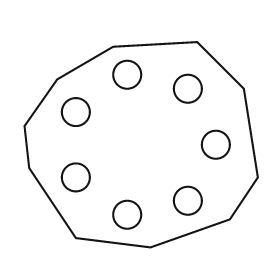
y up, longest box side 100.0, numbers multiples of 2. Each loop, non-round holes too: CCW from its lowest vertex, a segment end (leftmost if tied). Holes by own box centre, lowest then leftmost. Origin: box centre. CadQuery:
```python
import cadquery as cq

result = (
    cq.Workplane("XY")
    .moveTo(4.0, -44.0)
    .lineTo(38.0, -32.0)
    .lineTo(50.0, -14.0)
    .lineTo(44.0, 24.0)
    .lineTo(24.0, 44.0)
    .lineTo(-12.0, 42.0)
    .lineTo(-36.0, 28.0)
    .lineTo(-50.0, 8.0)
    .lineTo(-48.0, -10.0)
    .lineTo(-28.0, -40.0)
    .close()
    .moveTo(-6.0, -30.0)
    .circle(6.0)
    .moveTo(20.0, -24.0)
    .circle(6.0)
    .moveTo(-28.0, -14.0)
    .circle(6.0)
    .moveTo(32.0, 0.0)
    .circle(6.0)
    .moveTo(-28.0, 14.0)
    .circle(6.0)
    .moveTo(20.0, 24.0)
    .circle(6.0)
    .moveTo(-6.0, 30.0)
    .circle(6.0)
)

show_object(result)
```